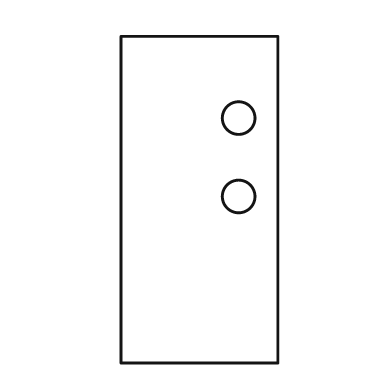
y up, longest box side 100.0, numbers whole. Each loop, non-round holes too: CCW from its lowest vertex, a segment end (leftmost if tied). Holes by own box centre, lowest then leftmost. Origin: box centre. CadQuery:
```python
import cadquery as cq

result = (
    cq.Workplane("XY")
    .moveTo(-24.0, -50.0)
    .lineTo(24.0, -50.0)
    .lineTo(24.0, 50.0)
    .lineTo(-24.0, 50.0)
    .close()
    .moveTo(12.0, 1.0)
    .circle(5.0)
    .moveTo(12.0, 25.0)
    .circle(5.0)
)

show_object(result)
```